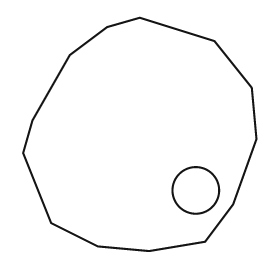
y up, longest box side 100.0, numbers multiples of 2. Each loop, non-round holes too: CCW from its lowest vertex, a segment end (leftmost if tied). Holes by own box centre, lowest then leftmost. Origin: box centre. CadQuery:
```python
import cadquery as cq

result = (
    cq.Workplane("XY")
    .moveTo(4.0, -50.0)
    .lineTo(28.0, -46.0)
    .lineTo(40.0, -30.0)
    .lineTo(50.0, -2.0)
    .lineTo(48.0, 20.0)
    .lineTo(32.0, 40.0)
    .lineTo(0.0, 50.0)
    .lineTo(-14.0, 46.0)
    .lineTo(-30.0, 34.0)
    .lineTo(-46.0, 6.0)
    .lineTo(-50.0, -8.0)
    .lineTo(-38.0, -38.0)
    .lineTo(-18.0, -48.0)
    .close()
    .moveTo(24.0, -24.0)
    .circle(10.0)
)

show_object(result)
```